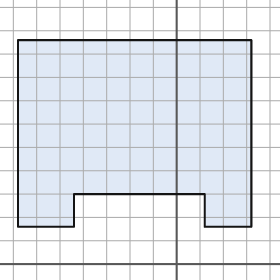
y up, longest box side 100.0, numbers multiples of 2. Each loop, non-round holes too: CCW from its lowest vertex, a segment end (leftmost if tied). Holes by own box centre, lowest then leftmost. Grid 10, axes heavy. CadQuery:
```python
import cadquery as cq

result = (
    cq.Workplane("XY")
    .moveTo(-68.0, 16.0)
    .lineTo(-44.0, 16.0)
    .lineTo(-44.0, 30.0)
    .lineTo(12.0, 30.0)
    .lineTo(12.0, 16.0)
    .lineTo(32.0, 16.0)
    .lineTo(32.0, 96.0)
    .lineTo(-68.0, 96.0)
    .close()
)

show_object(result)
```